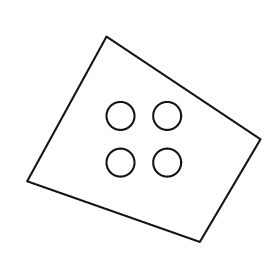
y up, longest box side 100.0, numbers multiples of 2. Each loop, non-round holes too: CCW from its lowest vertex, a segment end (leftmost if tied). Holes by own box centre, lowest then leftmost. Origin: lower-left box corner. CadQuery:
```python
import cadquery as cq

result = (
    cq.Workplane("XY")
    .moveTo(74.0, 0.0)
    .lineTo(100.0, 44.0)
    .lineTo(34.0, 88.0)
    .lineTo(0.0, 26.0)
    .close()
    .moveTo(40.0, 34.0)
    .circle(6.0)
    .moveTo(60.0, 34.0)
    .circle(6.0)
    .moveTo(40.0, 54.0)
    .circle(6.0)
    .moveTo(60.0, 54.0)
    .circle(6.0)
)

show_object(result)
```